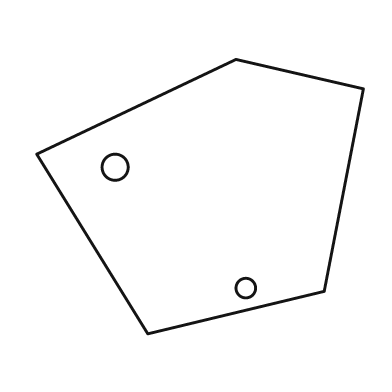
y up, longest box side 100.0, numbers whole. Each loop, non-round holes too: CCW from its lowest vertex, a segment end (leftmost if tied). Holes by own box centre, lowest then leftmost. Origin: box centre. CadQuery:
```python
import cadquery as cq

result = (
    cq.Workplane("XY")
    .moveTo(-16.0, -42.0)
    .lineTo(38.0, -29.0)
    .lineTo(50.0, 33.0)
    .lineTo(11.0, 42.0)
    .lineTo(-50.0, 13.0)
    .close()
    .moveTo(14.0, -28.0)
    .circle(3.0)
    .moveTo(-26.0, 9.0)
    .circle(4.0)
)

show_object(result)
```